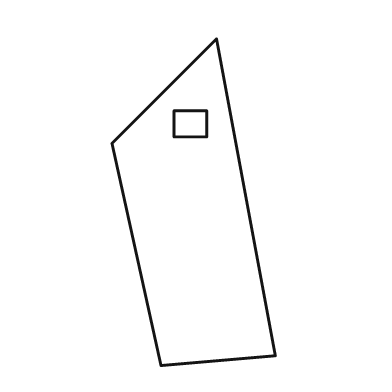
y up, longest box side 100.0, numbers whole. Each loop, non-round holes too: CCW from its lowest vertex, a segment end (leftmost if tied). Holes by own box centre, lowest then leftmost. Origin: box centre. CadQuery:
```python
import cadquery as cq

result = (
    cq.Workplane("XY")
    .moveTo(-10.0, -50.0)
    .lineTo(25.0, -47.0)
    .lineTo(7.0, 50.0)
    .lineTo(-25.0, 18.0)
    .close()
    .moveTo(-6.0, 20.0)
    .lineTo(4.0, 20.0)
    .lineTo(4.0, 28.0)
    .lineTo(-6.0, 28.0)
    .close()
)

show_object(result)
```